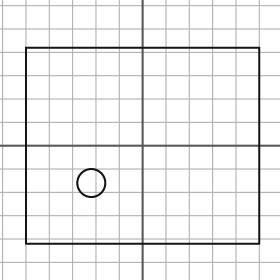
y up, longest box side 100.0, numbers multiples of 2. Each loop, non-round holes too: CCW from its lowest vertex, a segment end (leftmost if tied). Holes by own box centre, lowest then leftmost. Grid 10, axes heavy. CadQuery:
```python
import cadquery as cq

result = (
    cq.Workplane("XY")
    .moveTo(-50.0, -42.0)
    .lineTo(50.0, -42.0)
    .lineTo(50.0, 42.0)
    .lineTo(-50.0, 42.0)
    .close()
    .moveTo(-22.0, -16.0)
    .circle(6.0)
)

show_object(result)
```